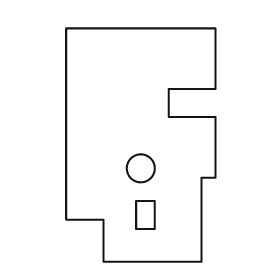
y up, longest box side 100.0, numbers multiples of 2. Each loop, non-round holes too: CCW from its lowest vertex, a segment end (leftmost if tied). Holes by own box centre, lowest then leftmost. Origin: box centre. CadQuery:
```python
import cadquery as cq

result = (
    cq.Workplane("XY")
    .moveTo(-16.0, -50.0)
    .lineTo(26.0, -50.0)
    .lineTo(26.0, -14.0)
    .lineTo(32.0, -14.0)
    .lineTo(32.0, 12.0)
    .lineTo(12.0, 12.0)
    .lineTo(12.0, 24.0)
    .lineTo(32.0, 24.0)
    .lineTo(32.0, 50.0)
    .lineTo(-32.0, 50.0)
    .lineTo(-32.0, -32.0)
    .lineTo(-16.0, -32.0)
    .close()
    .moveTo(-2.0, -36.0)
    .lineTo(6.0, -36.0)
    .lineTo(6.0, -24.0)
    .lineTo(-2.0, -24.0)
    .close()
    .moveTo(0.0, -10.0)
    .circle(6.0)
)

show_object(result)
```